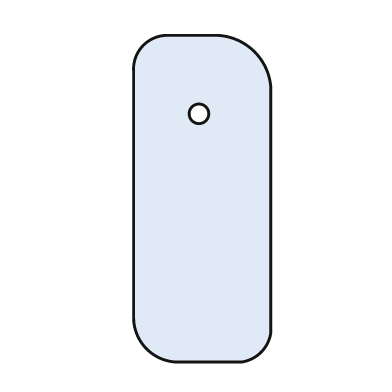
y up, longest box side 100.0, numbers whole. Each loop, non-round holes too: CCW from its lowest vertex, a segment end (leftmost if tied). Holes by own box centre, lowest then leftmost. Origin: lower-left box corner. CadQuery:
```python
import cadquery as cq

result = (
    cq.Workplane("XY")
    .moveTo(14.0, 0.0)
    .lineTo(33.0, 0.0)
    .threePointArc((39.0, 3.0), (42.0, 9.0))
    .lineTo(42.0, 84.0)
    .threePointArc((37.0, 95.0), (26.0, 100.0))
    .lineTo(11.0, 100.0)
    .threePointArc((3.0, 97.0), (0.0, 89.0))
    .lineTo(0.0, 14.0)
    .threePointArc((4.0, 4.0), (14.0, 0.0))
    .close()
    .moveTo(20.0, 76.0)
    .circle(3.0)
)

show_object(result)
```